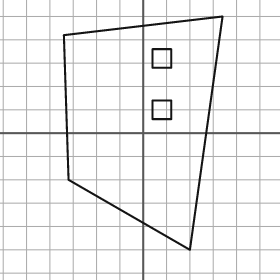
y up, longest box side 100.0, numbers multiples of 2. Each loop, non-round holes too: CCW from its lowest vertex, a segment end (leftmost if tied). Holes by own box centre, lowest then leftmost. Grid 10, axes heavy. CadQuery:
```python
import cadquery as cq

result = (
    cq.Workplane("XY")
    .moveTo(20.0, -50.0)
    .lineTo(34.0, 50.0)
    .lineTo(-34.0, 42.0)
    .lineTo(-32.0, -20.0)
    .close()
    .moveTo(4.0, 6.0)
    .lineTo(12.0, 6.0)
    .lineTo(12.0, 14.0)
    .lineTo(4.0, 14.0)
    .close()
    .moveTo(4.0, 28.0)
    .lineTo(12.0, 28.0)
    .lineTo(12.0, 36.0)
    .lineTo(4.0, 36.0)
    .close()
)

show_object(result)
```